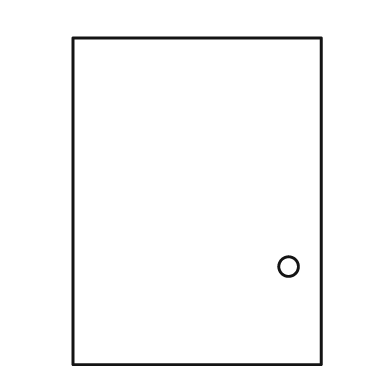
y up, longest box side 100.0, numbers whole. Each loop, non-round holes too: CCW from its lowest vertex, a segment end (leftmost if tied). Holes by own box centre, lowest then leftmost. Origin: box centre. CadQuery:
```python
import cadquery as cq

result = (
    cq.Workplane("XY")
    .moveTo(-38.0, -50.0)
    .lineTo(38.0, -50.0)
    .lineTo(38.0, 50.0)
    .lineTo(-38.0, 50.0)
    .close()
    .moveTo(28.0, -20.0)
    .circle(3.0)
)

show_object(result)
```